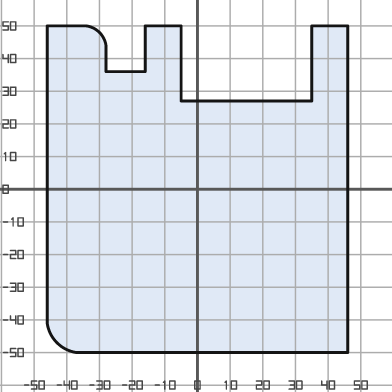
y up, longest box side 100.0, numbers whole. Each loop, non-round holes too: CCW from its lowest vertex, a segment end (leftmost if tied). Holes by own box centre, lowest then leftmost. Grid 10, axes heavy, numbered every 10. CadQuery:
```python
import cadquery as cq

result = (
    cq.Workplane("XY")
    .moveTo(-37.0, -50.0)
    .lineTo(46.0, -50.0)
    .lineTo(46.0, 50.0)
    .lineTo(35.0, 50.0)
    .lineTo(35.0, 27.0)
    .lineTo(-5.0, 27.0)
    .lineTo(-5.0, 50.0)
    .lineTo(-16.0, 50.0)
    .lineTo(-16.0, 36.0)
    .lineTo(-28.0, 36.0)
    .lineTo(-28.0, 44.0)
    .threePointArc((-30.0, 48.0), (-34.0, 50.0))
    .lineTo(-46.0, 50.0)
    .lineTo(-46.0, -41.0)
    .threePointArc((-43.0, -47.0), (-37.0, -50.0))
    .close()
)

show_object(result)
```